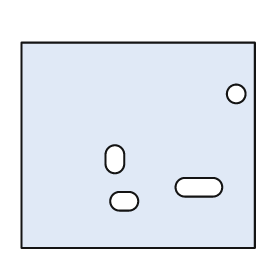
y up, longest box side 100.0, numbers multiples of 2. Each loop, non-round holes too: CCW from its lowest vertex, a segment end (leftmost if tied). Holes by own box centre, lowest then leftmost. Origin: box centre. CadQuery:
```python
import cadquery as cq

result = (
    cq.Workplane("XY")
    .moveTo(-50.0, -44.0)
    .lineTo(50.0, -44.0)
    .lineTo(50.0, 44.0)
    .lineTo(-50.0, 44.0)
    .close()
    .moveTo(-8.0, -28.0)
    .lineTo(-4.0, -28.0)
    .threePointArc((0.0, -24.0), (-4.0, -20.0))
    .lineTo(-8.0, -20.0)
    .threePointArc((-12.0, -24.0), (-8.0, -28.0))
    .close()
    .moveTo(20.0, -22.0)
    .lineTo(32.0, -22.0)
    .threePointArc((36.0, -18.0), (32.0, -14.0))
    .lineTo(20.0, -14.0)
    .threePointArc((16.0, -18.0), (20.0, -22.0))
    .close()
    .moveTo(-14.0, -8.0)
    .threePointArc((-10.0, -12.0), (-6.0, -8.0))
    .lineTo(-6.0, -4.0)
    .threePointArc((-10.0, 0.0), (-14.0, -4.0))
    .close()
    .moveTo(42.0, 22.0)
    .circle(4.0)
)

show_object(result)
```